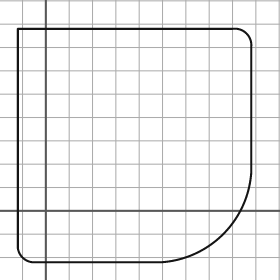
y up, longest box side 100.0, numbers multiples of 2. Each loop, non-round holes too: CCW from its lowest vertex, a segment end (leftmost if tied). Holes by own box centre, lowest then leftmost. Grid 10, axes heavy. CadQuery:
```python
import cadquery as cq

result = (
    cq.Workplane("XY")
    .moveTo(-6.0, -22.0)
    .lineTo(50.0, -22.0)
    .threePointArc((76.0, -10.0), (88.0, 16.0))
    .lineTo(88.0, 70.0)
    .threePointArc((86.0, 76.0), (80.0, 78.0))
    .lineTo(-12.0, 78.0)
    .lineTo(-12.0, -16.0)
    .threePointArc((-10.0, -20.0), (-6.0, -22.0))
    .close()
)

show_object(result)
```